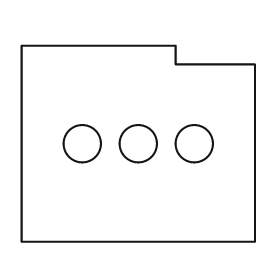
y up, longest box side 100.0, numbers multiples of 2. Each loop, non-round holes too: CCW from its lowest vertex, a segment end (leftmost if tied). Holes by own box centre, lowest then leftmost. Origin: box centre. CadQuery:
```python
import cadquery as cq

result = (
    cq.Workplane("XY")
    .moveTo(-50.0, -42.0)
    .lineTo(50.0, -42.0)
    .lineTo(50.0, 34.0)
    .lineTo(16.0, 34.0)
    .lineTo(16.0, 42.0)
    .lineTo(-50.0, 42.0)
    .close()
    .moveTo(-24.0, 0.0)
    .circle(8.0)
    .moveTo(0.0, 0.0)
    .circle(8.0)
    .moveTo(24.0, 0.0)
    .circle(8.0)
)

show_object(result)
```